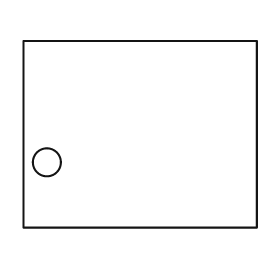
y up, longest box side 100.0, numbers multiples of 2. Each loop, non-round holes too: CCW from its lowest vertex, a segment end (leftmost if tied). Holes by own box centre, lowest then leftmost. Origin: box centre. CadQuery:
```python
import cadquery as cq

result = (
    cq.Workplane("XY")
    .moveTo(-50.0, -40.0)
    .lineTo(50.0, -40.0)
    .lineTo(50.0, 40.0)
    .lineTo(-50.0, 40.0)
    .close()
    .moveTo(-40.0, -12.0)
    .circle(6.0)
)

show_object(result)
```